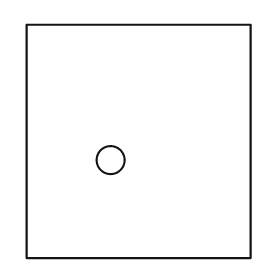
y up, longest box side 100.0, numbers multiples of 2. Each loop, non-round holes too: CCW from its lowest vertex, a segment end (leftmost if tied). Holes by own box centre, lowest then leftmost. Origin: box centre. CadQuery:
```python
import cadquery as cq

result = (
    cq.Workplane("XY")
    .moveTo(-48.0, -50.0)
    .lineTo(48.0, -50.0)
    .lineTo(48.0, 50.0)
    .lineTo(-48.0, 50.0)
    .close()
    .moveTo(-12.0, -8.0)
    .circle(6.0)
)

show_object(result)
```